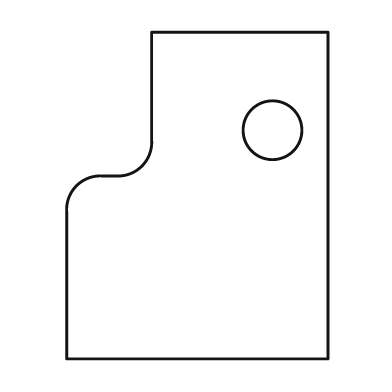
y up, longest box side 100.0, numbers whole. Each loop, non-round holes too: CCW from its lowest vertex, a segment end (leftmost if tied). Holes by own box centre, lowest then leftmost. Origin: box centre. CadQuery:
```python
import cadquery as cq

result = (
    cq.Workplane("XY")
    .moveTo(-40.0, -50.0)
    .lineTo(40.0, -50.0)
    .lineTo(40.0, 50.0)
    .lineTo(-14.0, 50.0)
    .lineTo(-14.0, 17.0)
    .threePointArc((-17.0, 9.0), (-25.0, 6.0))
    .lineTo(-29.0, 6.0)
    .threePointArc((-37.0, 3.0), (-40.0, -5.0))
    .close()
    .moveTo(23.0, 20.0)
    .circle(9.0)
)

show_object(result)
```